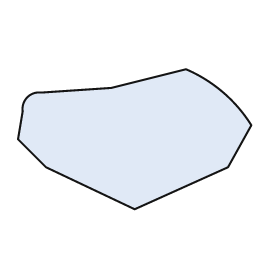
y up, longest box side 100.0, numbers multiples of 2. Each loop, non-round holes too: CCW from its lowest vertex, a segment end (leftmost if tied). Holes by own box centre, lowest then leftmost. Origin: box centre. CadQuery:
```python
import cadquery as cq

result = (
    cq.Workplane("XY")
    .moveTo(0.0, -30.0)
    .lineTo(40.0, -12.0)
    .lineTo(50.0, 6.0)
    .threePointArc((38.0, 20.0), (22.0, 30.0))
    .lineTo(-10.0, 22.0)
    .lineTo(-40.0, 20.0)
    .threePointArc((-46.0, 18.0), (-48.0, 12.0))
    .lineTo(-50.0, 0.0)
    .lineTo(-38.0, -12.0)
    .close()
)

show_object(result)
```